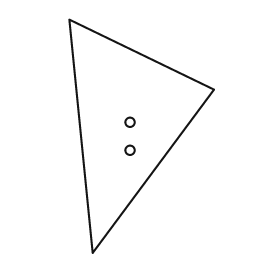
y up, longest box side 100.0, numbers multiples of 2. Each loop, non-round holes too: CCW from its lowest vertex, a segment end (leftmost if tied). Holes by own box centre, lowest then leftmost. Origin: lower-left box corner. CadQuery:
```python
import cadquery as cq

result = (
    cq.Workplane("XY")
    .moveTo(10.0, 0.0)
    .lineTo(62.0, 70.0)
    .lineTo(0.0, 100.0)
    .close()
    .moveTo(26.0, 44.0)
    .circle(2.0)
    .moveTo(26.0, 56.0)
    .circle(2.0)
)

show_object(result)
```